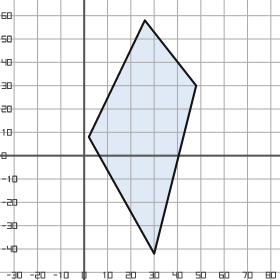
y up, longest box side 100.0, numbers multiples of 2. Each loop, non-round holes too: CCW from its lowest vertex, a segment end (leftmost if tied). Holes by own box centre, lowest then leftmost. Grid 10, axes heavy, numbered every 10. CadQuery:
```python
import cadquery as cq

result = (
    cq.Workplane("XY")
    .moveTo(30.0, -42.0)
    .lineTo(48.0, 30.0)
    .lineTo(26.0, 58.0)
    .lineTo(2.0, 8.0)
    .close()
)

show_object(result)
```